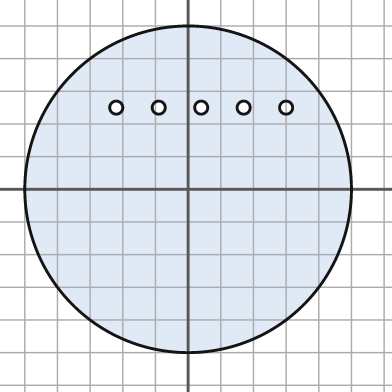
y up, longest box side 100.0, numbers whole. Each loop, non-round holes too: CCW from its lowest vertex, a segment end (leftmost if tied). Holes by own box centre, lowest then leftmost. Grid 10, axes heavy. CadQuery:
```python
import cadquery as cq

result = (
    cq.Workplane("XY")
    .moveTo(0.0, 0.0)
    .circle(50.0)
    .moveTo(-22.0, 25.0)
    .circle(2.0)
    .moveTo(-9.0, 25.0)
    .circle(2.0)
    .moveTo(4.0, 25.0)
    .circle(2.0)
    .moveTo(17.0, 25.0)
    .circle(2.0)
    .moveTo(30.0, 25.0)
    .circle(2.0)
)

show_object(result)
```